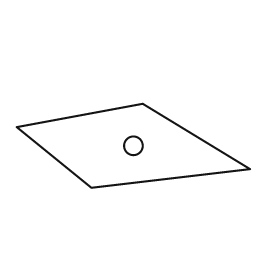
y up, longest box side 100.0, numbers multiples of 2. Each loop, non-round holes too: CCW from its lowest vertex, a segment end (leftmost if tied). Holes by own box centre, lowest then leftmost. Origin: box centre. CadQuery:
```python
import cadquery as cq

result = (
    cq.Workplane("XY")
    .moveTo(-18.0, -18.0)
    .lineTo(50.0, -10.0)
    .lineTo(4.0, 18.0)
    .lineTo(-50.0, 8.0)
    .close()
    .moveTo(0.0, 0.0)
    .circle(4.0)
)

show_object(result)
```